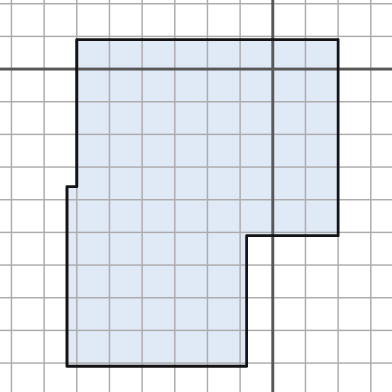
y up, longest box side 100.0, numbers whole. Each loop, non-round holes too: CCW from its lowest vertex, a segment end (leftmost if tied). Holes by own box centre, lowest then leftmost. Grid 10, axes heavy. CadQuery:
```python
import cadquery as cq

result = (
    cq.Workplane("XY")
    .moveTo(-63.0, -91.0)
    .lineTo(-8.0, -91.0)
    .lineTo(-8.0, -51.0)
    .lineTo(20.0, -51.0)
    .lineTo(20.0, 9.0)
    .lineTo(-60.0, 9.0)
    .lineTo(-60.0, -36.0)
    .lineTo(-63.0, -36.0)
    .close()
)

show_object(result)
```